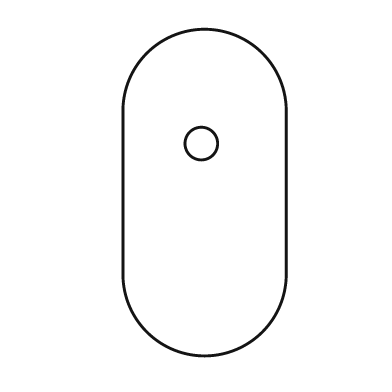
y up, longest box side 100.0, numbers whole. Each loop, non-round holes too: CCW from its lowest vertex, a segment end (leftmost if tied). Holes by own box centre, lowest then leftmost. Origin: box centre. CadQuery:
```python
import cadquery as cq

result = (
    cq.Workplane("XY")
    .moveTo(-25.0, -25.0)
    .threePointArc((0.0, -50.0), (25.0, -25.0))
    .lineTo(25.0, 25.0)
    .threePointArc((0.0, 50.0), (-25.0, 25.0))
    .close()
    .moveTo(-1.0, 15.0)
    .circle(5.0)
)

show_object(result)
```